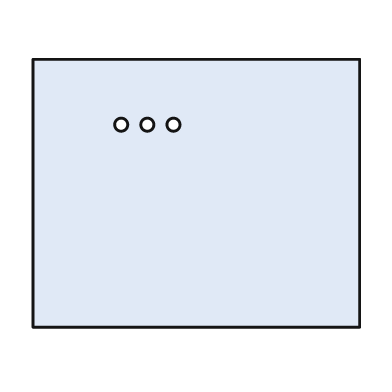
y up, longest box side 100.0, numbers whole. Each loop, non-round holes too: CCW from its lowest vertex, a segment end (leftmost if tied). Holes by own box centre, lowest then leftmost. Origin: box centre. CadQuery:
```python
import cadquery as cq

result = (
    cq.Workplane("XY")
    .moveTo(-50.0, -41.0)
    .lineTo(50.0, -41.0)
    .lineTo(50.0, 41.0)
    .lineTo(-50.0, 41.0)
    .close()
    .moveTo(-23.0, 21.0)
    .circle(2.0)
    .moveTo(-15.0, 21.0)
    .circle(2.0)
    .moveTo(-7.0, 21.0)
    .circle(2.0)
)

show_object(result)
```